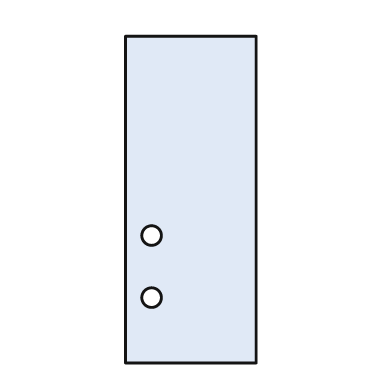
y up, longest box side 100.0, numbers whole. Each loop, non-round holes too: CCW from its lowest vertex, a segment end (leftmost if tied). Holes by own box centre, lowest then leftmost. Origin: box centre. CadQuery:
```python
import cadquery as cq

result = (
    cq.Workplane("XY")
    .moveTo(-20.0, -50.0)
    .lineTo(20.0, -50.0)
    .lineTo(20.0, 50.0)
    .lineTo(-20.0, 50.0)
    .close()
    .moveTo(-12.0, -30.0)
    .circle(3.0)
    .moveTo(-12.0, -11.0)
    .circle(3.0)
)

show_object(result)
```